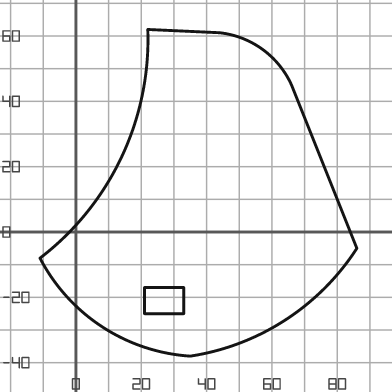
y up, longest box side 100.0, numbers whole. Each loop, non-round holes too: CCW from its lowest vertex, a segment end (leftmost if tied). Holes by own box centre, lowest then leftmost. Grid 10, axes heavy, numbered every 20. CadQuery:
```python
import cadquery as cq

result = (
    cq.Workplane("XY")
    .moveTo(35.0, -38.0)
    .threePointArc((64.0, -27.0), (86.0, -5.0))
    .lineTo(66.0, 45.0)
    .threePointArc((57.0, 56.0), (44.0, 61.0))
    .lineTo(22.0, 62.0)
    .threePointArc((14.0, 23.0), (-11.0, -8.0))
    .threePointArc((8.0, -29.0), (35.0, -38.0))
    .close()
    .moveTo(21.0, -25.0)
    .lineTo(33.0, -25.0)
    .lineTo(33.0, -17.0)
    .lineTo(21.0, -17.0)
    .close()
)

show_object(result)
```